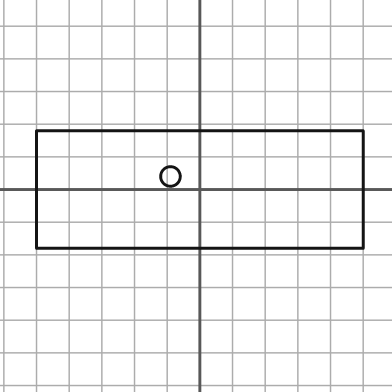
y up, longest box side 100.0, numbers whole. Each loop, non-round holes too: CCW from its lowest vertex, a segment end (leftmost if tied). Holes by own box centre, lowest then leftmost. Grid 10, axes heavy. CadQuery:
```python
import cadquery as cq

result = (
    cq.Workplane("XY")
    .moveTo(-50.0, -18.0)
    .lineTo(50.0, -18.0)
    .lineTo(50.0, 18.0)
    .lineTo(-50.0, 18.0)
    .close()
    .moveTo(-9.0, 4.0)
    .circle(3.0)
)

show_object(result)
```